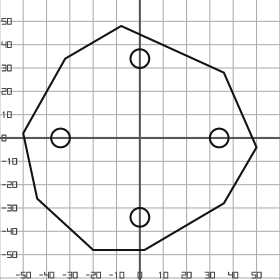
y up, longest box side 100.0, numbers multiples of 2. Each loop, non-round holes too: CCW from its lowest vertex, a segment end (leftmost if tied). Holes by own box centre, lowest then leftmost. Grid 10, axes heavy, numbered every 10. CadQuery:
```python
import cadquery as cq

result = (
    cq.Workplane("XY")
    .moveTo(-20.0, -48.0)
    .lineTo(2.0, -48.0)
    .lineTo(36.0, -28.0)
    .lineTo(50.0, -4.0)
    .lineTo(36.0, 28.0)
    .lineTo(-8.0, 48.0)
    .lineTo(-32.0, 34.0)
    .lineTo(-50.0, 2.0)
    .lineTo(-44.0, -26.0)
    .close()
    .moveTo(0.0, -34.0)
    .circle(4.0)
    .moveTo(-34.0, 0.0)
    .circle(4.0)
    .moveTo(34.0, 0.0)
    .circle(4.0)
    .moveTo(0.0, 34.0)
    .circle(4.0)
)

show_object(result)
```